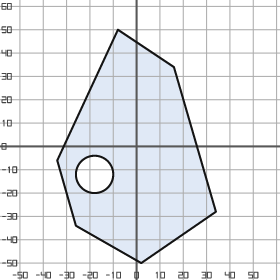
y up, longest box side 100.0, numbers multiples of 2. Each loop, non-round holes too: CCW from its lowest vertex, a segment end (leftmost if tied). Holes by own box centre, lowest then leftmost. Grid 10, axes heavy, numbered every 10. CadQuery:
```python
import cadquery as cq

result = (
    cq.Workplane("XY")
    .moveTo(2.0, -50.0)
    .lineTo(34.0, -28.0)
    .lineTo(16.0, 34.0)
    .lineTo(-8.0, 50.0)
    .lineTo(-34.0, -6.0)
    .lineTo(-26.0, -34.0)
    .close()
    .moveTo(-18.0, -12.0)
    .circle(8.0)
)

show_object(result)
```